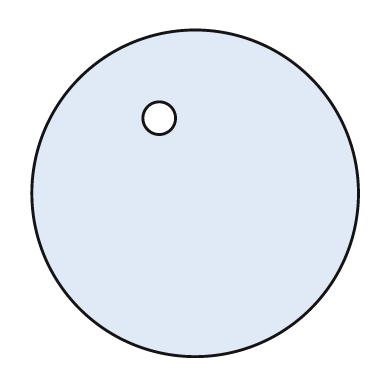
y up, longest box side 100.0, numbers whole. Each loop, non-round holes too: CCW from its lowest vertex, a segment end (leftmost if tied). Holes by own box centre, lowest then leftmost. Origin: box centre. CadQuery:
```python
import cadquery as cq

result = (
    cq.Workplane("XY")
    .moveTo(0.0, 0.0)
    .circle(50.0)
    .moveTo(-11.0, 23.0)
    .circle(5.0)
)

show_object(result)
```